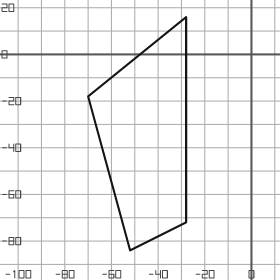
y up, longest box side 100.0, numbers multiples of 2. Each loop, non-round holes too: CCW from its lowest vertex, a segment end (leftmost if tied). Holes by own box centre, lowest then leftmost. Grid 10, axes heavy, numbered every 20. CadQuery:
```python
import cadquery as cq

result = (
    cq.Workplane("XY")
    .moveTo(-52.0, -84.0)
    .lineTo(-28.0, -72.0)
    .lineTo(-28.0, 16.0)
    .lineTo(-70.0, -18.0)
    .close()
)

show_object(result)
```